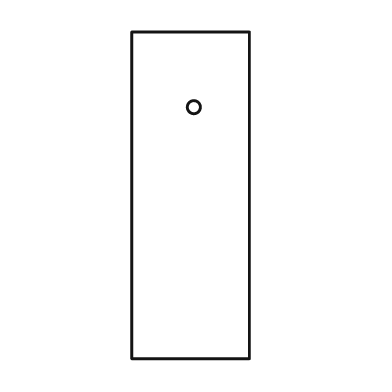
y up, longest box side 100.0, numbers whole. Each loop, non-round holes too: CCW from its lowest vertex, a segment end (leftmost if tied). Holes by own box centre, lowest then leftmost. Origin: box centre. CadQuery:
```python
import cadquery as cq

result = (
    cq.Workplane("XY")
    .moveTo(-18.0, -50.0)
    .lineTo(18.0, -50.0)
    .lineTo(18.0, 50.0)
    .lineTo(-18.0, 50.0)
    .close()
    .moveTo(1.0, 27.0)
    .circle(2.0)
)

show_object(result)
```